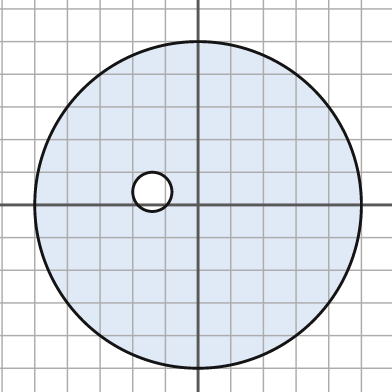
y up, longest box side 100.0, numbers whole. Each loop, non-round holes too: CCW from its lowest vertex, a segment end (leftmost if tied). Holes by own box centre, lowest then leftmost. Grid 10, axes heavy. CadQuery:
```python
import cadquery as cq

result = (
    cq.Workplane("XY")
    .moveTo(0.0, 0.0)
    .circle(50.0)
    .moveTo(-14.0, 4.0)
    .circle(6.0)
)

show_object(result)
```